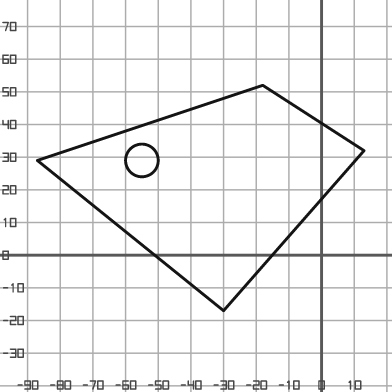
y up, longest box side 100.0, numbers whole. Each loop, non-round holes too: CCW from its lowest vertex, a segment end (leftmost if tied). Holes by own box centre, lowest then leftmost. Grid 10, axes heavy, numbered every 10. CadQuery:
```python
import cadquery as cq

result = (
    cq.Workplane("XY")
    .moveTo(-30.0, -17.0)
    .lineTo(13.0, 32.0)
    .lineTo(-18.0, 52.0)
    .lineTo(-87.0, 29.0)
    .close()
    .moveTo(-55.0, 29.0)
    .circle(5.0)
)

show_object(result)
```